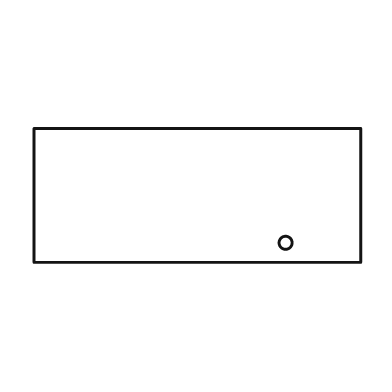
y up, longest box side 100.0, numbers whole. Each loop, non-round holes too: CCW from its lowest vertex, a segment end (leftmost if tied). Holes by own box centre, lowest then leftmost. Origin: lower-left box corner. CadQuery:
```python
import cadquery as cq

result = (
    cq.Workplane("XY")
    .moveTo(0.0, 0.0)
    .lineTo(100.0, 0.0)
    .lineTo(100.0, 41.0)
    .lineTo(0.0, 41.0)
    .close()
    .moveTo(77.0, 6.0)
    .circle(2.0)
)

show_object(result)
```